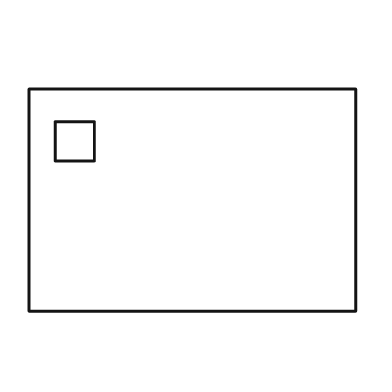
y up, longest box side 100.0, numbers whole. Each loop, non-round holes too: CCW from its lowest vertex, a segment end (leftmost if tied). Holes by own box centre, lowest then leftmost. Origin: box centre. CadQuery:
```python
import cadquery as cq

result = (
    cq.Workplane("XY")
    .moveTo(-50.0, -34.0)
    .lineTo(50.0, -34.0)
    .lineTo(50.0, 34.0)
    .lineTo(-50.0, 34.0)
    .close()
    .moveTo(-42.0, 12.0)
    .lineTo(-30.0, 12.0)
    .lineTo(-30.0, 24.0)
    .lineTo(-42.0, 24.0)
    .close()
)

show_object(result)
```